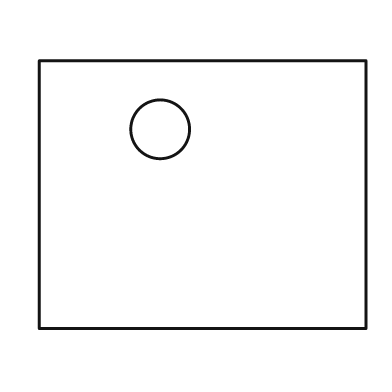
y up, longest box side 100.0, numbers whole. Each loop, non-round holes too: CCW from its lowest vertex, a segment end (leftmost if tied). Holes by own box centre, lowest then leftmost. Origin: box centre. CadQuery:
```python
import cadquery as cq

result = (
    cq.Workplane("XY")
    .moveTo(-50.0, -41.0)
    .lineTo(50.0, -41.0)
    .lineTo(50.0, 41.0)
    .lineTo(-50.0, 41.0)
    .close()
    .moveTo(-13.0, 20.0)
    .circle(9.0)
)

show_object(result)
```